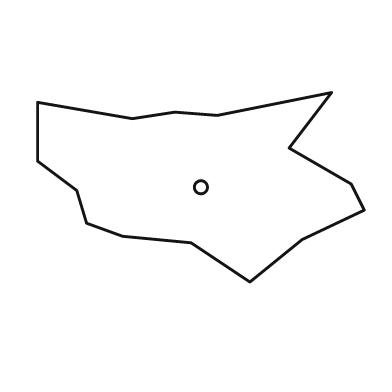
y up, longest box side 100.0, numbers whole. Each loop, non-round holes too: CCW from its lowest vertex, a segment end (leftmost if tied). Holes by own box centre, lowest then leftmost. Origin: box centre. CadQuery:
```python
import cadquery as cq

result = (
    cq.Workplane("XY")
    .moveTo(15.0, -29.0)
    .lineTo(31.0, -16.0)
    .lineTo(50.0, -7.0)
    .lineTo(46.0, 1.0)
    .lineTo(27.0, 12.0)
    .lineTo(40.0, 29.0)
    .lineTo(5.0, 22.0)
    .lineTo(-8.0, 23.0)
    .lineTo(-21.0, 21.0)
    .lineTo(-50.0, 26.0)
    .lineTo(-50.0, 8.0)
    .lineTo(-38.0, -1.0)
    .lineTo(-35.0, -11.0)
    .lineTo(-24.0, -15.0)
    .lineTo(-3.0, -17.0)
    .close()
    .moveTo(0.0, 0.0)
    .circle(2.0)
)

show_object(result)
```